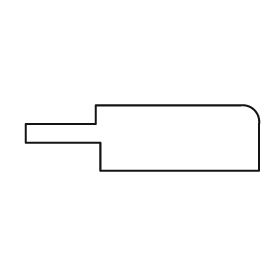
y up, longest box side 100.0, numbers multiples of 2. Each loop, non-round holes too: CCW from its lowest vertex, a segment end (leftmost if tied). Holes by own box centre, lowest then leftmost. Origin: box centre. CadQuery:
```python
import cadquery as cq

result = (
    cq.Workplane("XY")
    .moveTo(-18.0, -14.0)
    .lineTo(50.0, -14.0)
    .lineTo(50.0, 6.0)
    .threePointArc((48.0, 12.0), (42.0, 14.0))
    .lineTo(-20.0, 14.0)
    .lineTo(-20.0, 6.0)
    .lineTo(-50.0, 6.0)
    .lineTo(-50.0, -2.0)
    .lineTo(-18.0, -2.0)
    .close()
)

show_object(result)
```